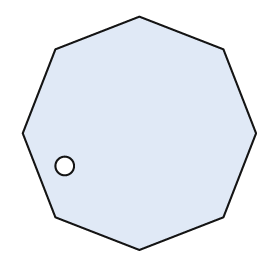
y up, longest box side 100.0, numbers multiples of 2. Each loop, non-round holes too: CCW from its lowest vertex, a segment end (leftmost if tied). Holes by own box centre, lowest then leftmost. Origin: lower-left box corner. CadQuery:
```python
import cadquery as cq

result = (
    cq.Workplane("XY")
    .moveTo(50.0, 0.0)
    .lineTo(86.0, 14.0)
    .lineTo(100.0, 50.0)
    .lineTo(86.0, 86.0)
    .lineTo(50.0, 100.0)
    .lineTo(14.0, 86.0)
    .lineTo(0.0, 50.0)
    .lineTo(14.0, 14.0)
    .close()
    .moveTo(18.0, 36.0)
    .circle(4.0)
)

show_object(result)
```